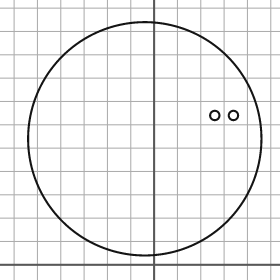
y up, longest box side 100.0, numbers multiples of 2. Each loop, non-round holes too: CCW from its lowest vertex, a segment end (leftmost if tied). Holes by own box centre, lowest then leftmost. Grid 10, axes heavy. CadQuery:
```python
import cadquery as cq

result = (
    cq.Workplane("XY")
    .moveTo(-4.0, 54.0)
    .circle(50.0)
    .moveTo(26.0, 64.0)
    .circle(2.0)
    .moveTo(34.0, 64.0)
    .circle(2.0)
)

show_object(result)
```